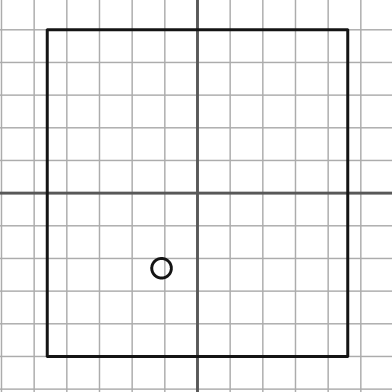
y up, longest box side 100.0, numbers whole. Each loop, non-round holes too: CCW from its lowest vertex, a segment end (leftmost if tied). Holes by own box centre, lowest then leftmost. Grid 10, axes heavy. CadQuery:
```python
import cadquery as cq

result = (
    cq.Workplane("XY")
    .moveTo(-46.0, -50.0)
    .lineTo(46.0, -50.0)
    .lineTo(46.0, 50.0)
    .lineTo(-46.0, 50.0)
    .close()
    .moveTo(-11.0, -23.0)
    .circle(3.0)
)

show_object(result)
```